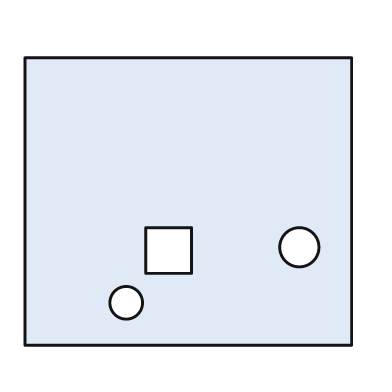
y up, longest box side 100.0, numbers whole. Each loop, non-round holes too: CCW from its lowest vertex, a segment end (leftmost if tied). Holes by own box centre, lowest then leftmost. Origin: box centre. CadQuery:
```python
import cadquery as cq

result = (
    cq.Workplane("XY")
    .moveTo(-50.0, -44.0)
    .lineTo(50.0, -44.0)
    .lineTo(50.0, 44.0)
    .lineTo(-50.0, 44.0)
    .close()
    .moveTo(-19.0, -31.0)
    .circle(5.0)
    .moveTo(-13.0, -22.0)
    .lineTo(1.0, -22.0)
    .lineTo(1.0, -8.0)
    .lineTo(-13.0, -8.0)
    .close()
    .moveTo(34.0, -14.0)
    .circle(6.0)
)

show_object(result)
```